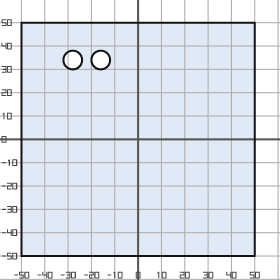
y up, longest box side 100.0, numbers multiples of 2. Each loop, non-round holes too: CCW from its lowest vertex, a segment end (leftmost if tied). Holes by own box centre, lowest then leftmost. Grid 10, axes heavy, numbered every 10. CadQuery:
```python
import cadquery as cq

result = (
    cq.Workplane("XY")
    .moveTo(-50.0, -50.0)
    .lineTo(50.0, -50.0)
    .lineTo(50.0, 50.0)
    .lineTo(-50.0, 50.0)
    .close()
    .moveTo(-28.0, 34.0)
    .circle(4.0)
    .moveTo(-16.0, 34.0)
    .circle(4.0)
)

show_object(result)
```